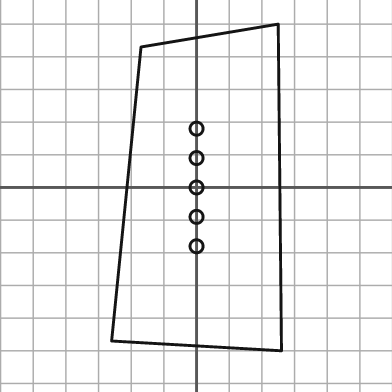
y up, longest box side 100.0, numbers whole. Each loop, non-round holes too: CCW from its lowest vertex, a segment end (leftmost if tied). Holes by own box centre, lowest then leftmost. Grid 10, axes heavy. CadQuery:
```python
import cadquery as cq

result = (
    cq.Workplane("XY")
    .moveTo(26.0, -50.0)
    .lineTo(25.0, 50.0)
    .lineTo(-17.0, 43.0)
    .lineTo(-26.0, -47.0)
    .close()
    .moveTo(0.0, -18.0)
    .circle(2.0)
    .moveTo(0.0, -9.0)
    .circle(2.0)
    .moveTo(0.0, 0.0)
    .circle(2.0)
    .moveTo(0.0, 9.0)
    .circle(2.0)
    .moveTo(0.0, 18.0)
    .circle(2.0)
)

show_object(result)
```